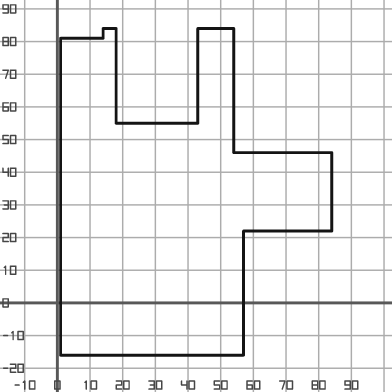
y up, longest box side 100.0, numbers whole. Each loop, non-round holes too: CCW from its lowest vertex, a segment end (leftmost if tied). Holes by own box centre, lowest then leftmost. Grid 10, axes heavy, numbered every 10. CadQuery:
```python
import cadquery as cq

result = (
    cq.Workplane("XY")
    .moveTo(1.0, -16.0)
    .lineTo(57.0, -16.0)
    .lineTo(57.0, 22.0)
    .lineTo(84.0, 22.0)
    .lineTo(84.0, 46.0)
    .lineTo(54.0, 46.0)
    .lineTo(54.0, 84.0)
    .lineTo(43.0, 84.0)
    .lineTo(43.0, 55.0)
    .lineTo(18.0, 55.0)
    .lineTo(18.0, 84.0)
    .lineTo(14.0, 84.0)
    .lineTo(14.0, 81.0)
    .lineTo(1.0, 81.0)
    .close()
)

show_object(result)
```